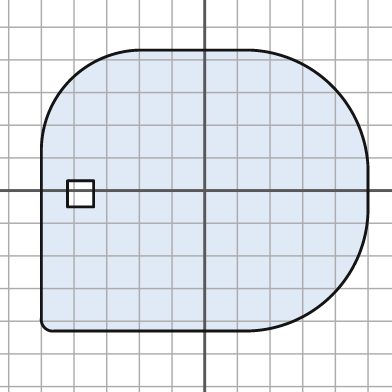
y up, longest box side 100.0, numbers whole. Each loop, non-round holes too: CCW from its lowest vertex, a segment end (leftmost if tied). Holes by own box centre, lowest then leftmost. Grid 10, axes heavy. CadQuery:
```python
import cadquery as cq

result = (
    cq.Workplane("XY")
    .moveTo(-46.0, -43.0)
    .lineTo(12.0, -43.0)
    .threePointArc((39.0, -32.0), (50.0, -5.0))
    .lineTo(50.0, 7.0)
    .threePointArc((39.0, 32.0), (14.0, 43.0))
    .lineTo(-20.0, 43.0)
    .threePointArc((-41.0, 34.0), (-50.0, 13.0))
    .lineTo(-50.0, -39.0)
    .threePointArc((-49.0, -42.0), (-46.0, -43.0))
    .close()
    .moveTo(-42.0, -5.0)
    .lineTo(-34.0, -5.0)
    .lineTo(-34.0, 3.0)
    .lineTo(-42.0, 3.0)
    .close()
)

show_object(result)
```